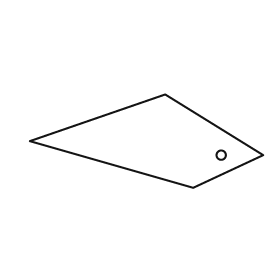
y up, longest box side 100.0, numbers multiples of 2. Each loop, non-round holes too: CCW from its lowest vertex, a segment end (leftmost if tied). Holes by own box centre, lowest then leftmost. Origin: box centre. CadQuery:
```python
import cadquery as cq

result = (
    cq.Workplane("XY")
    .moveTo(20.0, -20.0)
    .lineTo(50.0, -6.0)
    .lineTo(8.0, 20.0)
    .lineTo(-50.0, 0.0)
    .close()
    .moveTo(32.0, -6.0)
    .circle(2.0)
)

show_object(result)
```